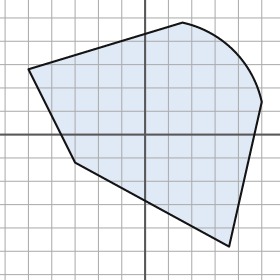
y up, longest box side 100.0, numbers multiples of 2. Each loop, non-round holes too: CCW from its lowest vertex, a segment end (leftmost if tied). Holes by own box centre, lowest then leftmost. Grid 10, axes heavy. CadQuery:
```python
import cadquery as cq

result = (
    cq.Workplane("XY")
    .moveTo(36.0, -48.0)
    .lineTo(50.0, 14.0)
    .threePointArc((38.0, 36.0), (16.0, 48.0))
    .lineTo(-50.0, 28.0)
    .lineTo(-30.0, -12.0)
    .close()
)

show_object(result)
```